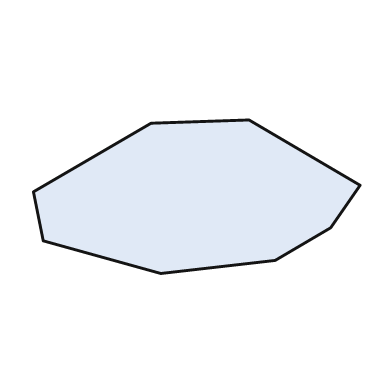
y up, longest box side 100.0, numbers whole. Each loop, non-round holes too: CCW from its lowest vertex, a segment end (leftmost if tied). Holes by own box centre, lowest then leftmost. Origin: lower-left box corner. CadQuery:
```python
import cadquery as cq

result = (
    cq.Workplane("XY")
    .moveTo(39.0, 0.0)
    .lineTo(74.0, 4.0)
    .lineTo(91.0, 14.0)
    .lineTo(100.0, 27.0)
    .lineTo(66.0, 47.0)
    .lineTo(36.0, 46.0)
    .lineTo(0.0, 25.0)
    .lineTo(3.0, 10.0)
    .close()
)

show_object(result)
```